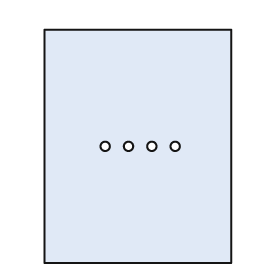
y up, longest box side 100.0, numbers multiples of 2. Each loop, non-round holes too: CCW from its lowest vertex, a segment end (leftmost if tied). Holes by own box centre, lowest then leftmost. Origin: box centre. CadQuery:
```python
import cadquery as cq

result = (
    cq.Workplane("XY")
    .moveTo(-40.0, -50.0)
    .lineTo(40.0, -50.0)
    .lineTo(40.0, 50.0)
    .lineTo(-40.0, 50.0)
    .close()
    .moveTo(-14.0, 0.0)
    .circle(2.0)
    .moveTo(-4.0, 0.0)
    .circle(2.0)
    .moveTo(6.0, 0.0)
    .circle(2.0)
    .moveTo(16.0, 0.0)
    .circle(2.0)
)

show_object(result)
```